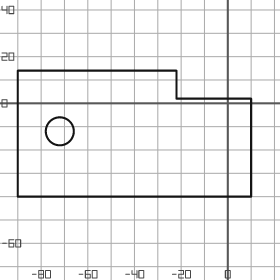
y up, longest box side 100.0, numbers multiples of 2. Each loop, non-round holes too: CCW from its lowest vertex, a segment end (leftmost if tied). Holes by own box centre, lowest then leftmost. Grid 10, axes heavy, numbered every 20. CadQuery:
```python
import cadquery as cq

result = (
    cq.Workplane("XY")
    .moveTo(-90.0, -40.0)
    .lineTo(10.0, -40.0)
    .lineTo(10.0, 2.0)
    .lineTo(-22.0, 2.0)
    .lineTo(-22.0, 14.0)
    .lineTo(-90.0, 14.0)
    .close()
    .moveTo(-72.0, -12.0)
    .circle(6.0)
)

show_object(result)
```